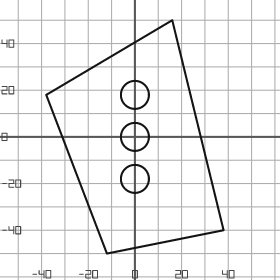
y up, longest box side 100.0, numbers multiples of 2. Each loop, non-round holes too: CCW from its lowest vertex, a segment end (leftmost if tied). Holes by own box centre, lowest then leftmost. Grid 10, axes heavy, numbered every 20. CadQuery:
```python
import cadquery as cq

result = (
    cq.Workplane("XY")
    .moveTo(-12.0, -50.0)
    .lineTo(38.0, -40.0)
    .lineTo(16.0, 50.0)
    .lineTo(-38.0, 18.0)
    .close()
    .moveTo(0.0, -18.0)
    .circle(6.0)
    .moveTo(0.0, 0.0)
    .circle(6.0)
    .moveTo(0.0, 18.0)
    .circle(6.0)
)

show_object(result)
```